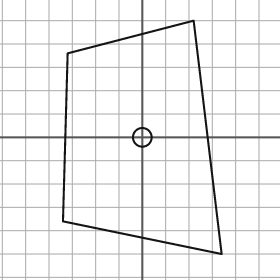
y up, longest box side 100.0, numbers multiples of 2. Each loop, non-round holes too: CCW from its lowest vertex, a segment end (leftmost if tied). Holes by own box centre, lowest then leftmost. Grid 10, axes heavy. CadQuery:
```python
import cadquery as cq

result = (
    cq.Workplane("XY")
    .moveTo(34.0, -50.0)
    .lineTo(22.0, 50.0)
    .lineTo(-32.0, 36.0)
    .lineTo(-34.0, -36.0)
    .close()
    .moveTo(0.0, 0.0)
    .circle(4.0)
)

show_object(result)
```